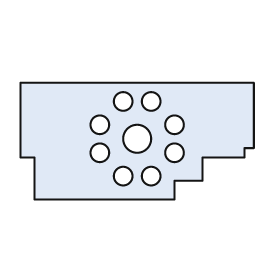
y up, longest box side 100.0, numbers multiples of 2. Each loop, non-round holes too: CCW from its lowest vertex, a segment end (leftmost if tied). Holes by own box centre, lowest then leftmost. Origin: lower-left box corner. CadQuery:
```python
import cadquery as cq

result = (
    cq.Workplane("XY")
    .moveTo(6.0, 0.0)
    .lineTo(66.0, 0.0)
    .lineTo(66.0, 8.0)
    .lineTo(78.0, 8.0)
    .lineTo(78.0, 18.0)
    .lineTo(96.0, 18.0)
    .lineTo(96.0, 22.0)
    .lineTo(100.0, 22.0)
    .lineTo(100.0, 50.0)
    .lineTo(0.0, 50.0)
    .lineTo(0.0, 18.0)
    .lineTo(6.0, 18.0)
    .close()
    .moveTo(44.0, 10.0)
    .circle(4.0)
    .moveTo(56.0, 10.0)
    .circle(4.0)
    .moveTo(34.0, 20.0)
    .circle(4.0)
    .moveTo(66.0, 20.0)
    .circle(4.0)
    .moveTo(50.0, 26.0)
    .circle(6.0)
    .moveTo(34.0, 32.0)
    .circle(4.0)
    .moveTo(66.0, 32.0)
    .circle(4.0)
    .moveTo(44.0, 42.0)
    .circle(4.0)
    .moveTo(56.0, 42.0)
    .circle(4.0)
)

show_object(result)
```